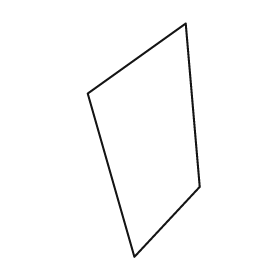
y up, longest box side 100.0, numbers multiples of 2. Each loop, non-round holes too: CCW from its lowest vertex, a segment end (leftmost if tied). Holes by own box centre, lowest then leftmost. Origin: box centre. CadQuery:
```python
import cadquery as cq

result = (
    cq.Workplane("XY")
    .moveTo(-4.0, -50.0)
    .lineTo(24.0, -20.0)
    .lineTo(18.0, 50.0)
    .lineTo(-24.0, 20.0)
    .close()
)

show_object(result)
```